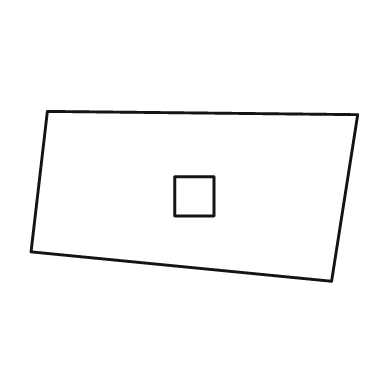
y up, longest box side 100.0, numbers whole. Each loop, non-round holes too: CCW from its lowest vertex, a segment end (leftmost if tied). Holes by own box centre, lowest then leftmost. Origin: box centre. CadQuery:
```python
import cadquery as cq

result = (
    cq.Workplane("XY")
    .moveTo(42.0, -26.0)
    .lineTo(50.0, 25.0)
    .lineTo(-45.0, 26.0)
    .lineTo(-50.0, -17.0)
    .close()
    .moveTo(-6.0, -6.0)
    .lineTo(6.0, -6.0)
    .lineTo(6.0, 6.0)
    .lineTo(-6.0, 6.0)
    .close()
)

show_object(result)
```